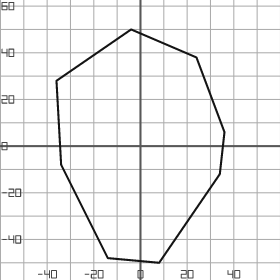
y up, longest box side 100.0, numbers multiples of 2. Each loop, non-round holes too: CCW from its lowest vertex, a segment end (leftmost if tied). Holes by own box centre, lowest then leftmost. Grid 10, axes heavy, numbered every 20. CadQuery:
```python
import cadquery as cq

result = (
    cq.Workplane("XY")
    .moveTo(8.0, -50.0)
    .lineTo(34.0, -12.0)
    .lineTo(36.0, 6.0)
    .lineTo(24.0, 38.0)
    .lineTo(-4.0, 50.0)
    .lineTo(-36.0, 28.0)
    .lineTo(-34.0, -8.0)
    .lineTo(-14.0, -48.0)
    .close()
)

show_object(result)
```